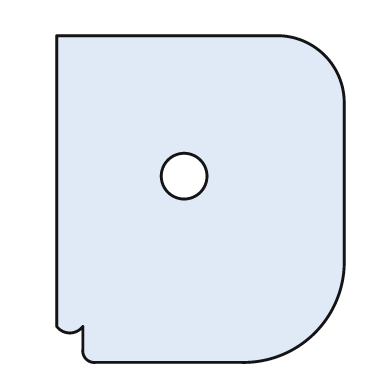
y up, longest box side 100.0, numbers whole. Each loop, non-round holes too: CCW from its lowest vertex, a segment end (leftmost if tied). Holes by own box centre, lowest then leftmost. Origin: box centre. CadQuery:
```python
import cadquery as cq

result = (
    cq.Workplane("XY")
    .moveTo(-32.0, -50.0)
    .lineTo(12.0, -50.0)
    .threePointArc((35.0, -41.0), (44.0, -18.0))
    .lineTo(44.0, 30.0)
    .threePointArc((38.0, 44.0), (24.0, 50.0))
    .lineTo(-44.0, 50.0)
    .lineTo(-44.0, -39.0)
    .threePointArc((-40.0, -41.0), (-36.0, -39.0))
    .lineTo(-36.0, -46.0)
    .threePointArc((-35.0, -49.0), (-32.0, -50.0))
    .close()
    .moveTo(-5.0, 7.0)
    .circle(7.0)
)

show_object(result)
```